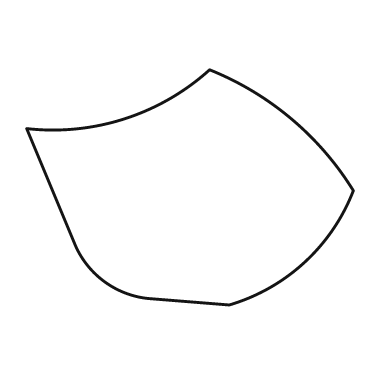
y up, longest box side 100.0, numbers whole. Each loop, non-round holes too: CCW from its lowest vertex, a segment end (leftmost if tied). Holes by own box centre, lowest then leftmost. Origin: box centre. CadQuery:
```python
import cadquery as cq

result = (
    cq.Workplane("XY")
    .moveTo(12.0, -36.0)
    .threePointArc((35.0, -23.0), (50.0, -1.0))
    .threePointArc((31.0, 21.0), (6.0, 36.0))
    .threePointArc((-20.0, 21.0), (-50.0, 18.0))
    .lineTo(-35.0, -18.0)
    .threePointArc((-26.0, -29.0), (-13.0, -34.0))
    .close()
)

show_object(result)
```